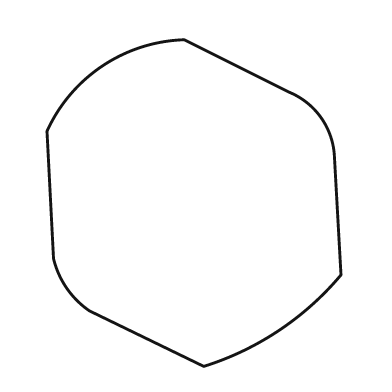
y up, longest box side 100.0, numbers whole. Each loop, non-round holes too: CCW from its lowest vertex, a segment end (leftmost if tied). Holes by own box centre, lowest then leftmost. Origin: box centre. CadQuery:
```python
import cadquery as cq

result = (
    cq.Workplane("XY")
    .moveTo(3.0, -50.0)
    .threePointArc((26.0, -39.0), (45.0, -22.0))
    .lineTo(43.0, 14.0)
    .threePointArc((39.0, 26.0), (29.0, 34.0))
    .lineTo(-3.0, 50.0)
    .threePointArc((-28.0, 42.0), (-45.0, 22.0))
    .lineTo(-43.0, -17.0)
    .threePointArc((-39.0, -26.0), (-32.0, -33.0))
    .close()
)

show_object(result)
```